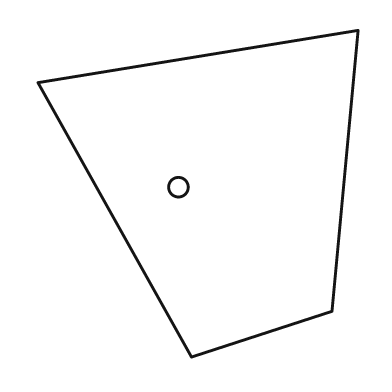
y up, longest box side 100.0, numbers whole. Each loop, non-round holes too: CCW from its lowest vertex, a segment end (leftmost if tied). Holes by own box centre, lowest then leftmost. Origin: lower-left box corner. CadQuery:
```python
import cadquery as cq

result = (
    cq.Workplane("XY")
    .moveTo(47.0, 0.0)
    .lineTo(90.0, 14.0)
    .lineTo(98.0, 100.0)
    .lineTo(0.0, 84.0)
    .close()
    .moveTo(43.0, 52.0)
    .circle(3.0)
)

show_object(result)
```